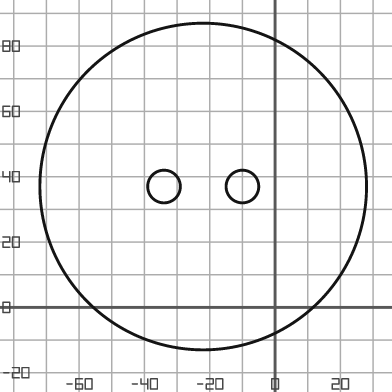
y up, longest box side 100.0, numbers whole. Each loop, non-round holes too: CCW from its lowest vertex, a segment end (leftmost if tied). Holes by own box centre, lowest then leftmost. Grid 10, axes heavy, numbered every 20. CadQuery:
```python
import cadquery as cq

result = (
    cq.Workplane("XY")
    .moveTo(-22.0, 37.0)
    .circle(50.0)
    .moveTo(-34.0, 37.0)
    .circle(5.0)
    .moveTo(-10.0, 37.0)
    .circle(5.0)
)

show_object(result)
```